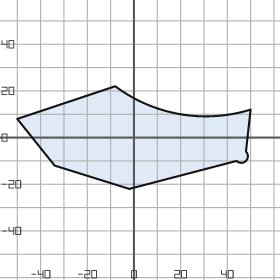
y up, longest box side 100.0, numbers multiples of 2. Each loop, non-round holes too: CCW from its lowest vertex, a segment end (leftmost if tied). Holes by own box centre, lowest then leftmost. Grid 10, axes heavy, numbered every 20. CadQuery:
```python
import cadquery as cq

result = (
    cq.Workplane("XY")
    .moveTo(-2.0, -22.0)
    .lineTo(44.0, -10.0)
    .threePointArc((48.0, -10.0), (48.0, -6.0))
    .lineTo(50.0, 12.0)
    .threePointArc((20.0, 10.0), (-8.0, 22.0))
    .lineTo(-50.0, 8.0)
    .lineTo(-34.0, -12.0)
    .close()
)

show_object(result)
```